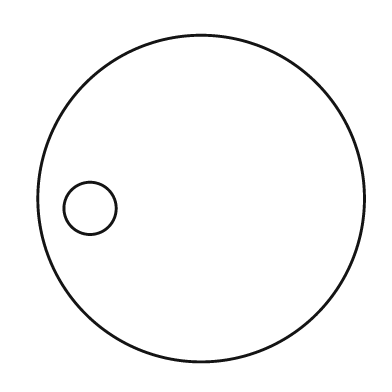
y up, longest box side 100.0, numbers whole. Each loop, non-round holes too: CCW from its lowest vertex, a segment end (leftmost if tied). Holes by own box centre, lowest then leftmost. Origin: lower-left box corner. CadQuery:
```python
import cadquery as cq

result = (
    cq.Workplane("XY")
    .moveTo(50.0, 50.0)
    .circle(50.0)
    .moveTo(16.0, 47.0)
    .circle(8.0)
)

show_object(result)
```